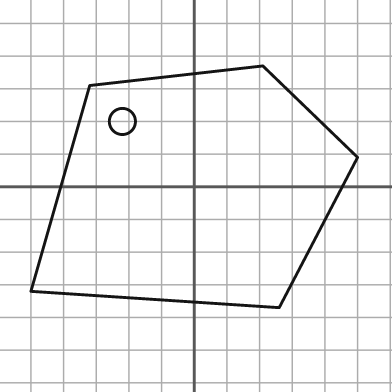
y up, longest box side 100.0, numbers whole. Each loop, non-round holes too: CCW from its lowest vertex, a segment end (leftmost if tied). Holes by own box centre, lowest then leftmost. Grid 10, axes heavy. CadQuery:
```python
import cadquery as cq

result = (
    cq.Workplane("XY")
    .moveTo(26.0, -37.0)
    .lineTo(50.0, 9.0)
    .lineTo(21.0, 37.0)
    .lineTo(-32.0, 31.0)
    .lineTo(-50.0, -32.0)
    .close()
    .moveTo(-22.0, 20.0)
    .circle(4.0)
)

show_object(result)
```